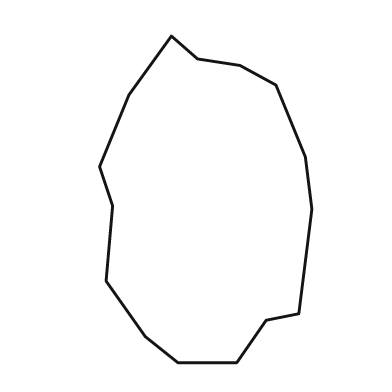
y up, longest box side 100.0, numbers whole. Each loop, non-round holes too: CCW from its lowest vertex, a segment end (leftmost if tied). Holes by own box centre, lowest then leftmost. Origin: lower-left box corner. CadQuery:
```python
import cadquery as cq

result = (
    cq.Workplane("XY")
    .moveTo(24.0, 0.0)
    .lineTo(42.0, 0.0)
    .lineTo(51.0, 13.0)
    .lineTo(61.0, 15.0)
    .lineTo(65.0, 47.0)
    .lineTo(63.0, 63.0)
    .lineTo(54.0, 85.0)
    .lineTo(43.0, 91.0)
    .lineTo(30.0, 93.0)
    .lineTo(22.0, 100.0)
    .lineTo(9.0, 82.0)
    .lineTo(0.0, 60.0)
    .lineTo(4.0, 48.0)
    .lineTo(2.0, 25.0)
    .lineTo(14.0, 8.0)
    .close()
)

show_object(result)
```